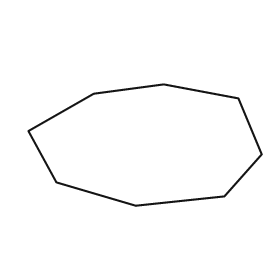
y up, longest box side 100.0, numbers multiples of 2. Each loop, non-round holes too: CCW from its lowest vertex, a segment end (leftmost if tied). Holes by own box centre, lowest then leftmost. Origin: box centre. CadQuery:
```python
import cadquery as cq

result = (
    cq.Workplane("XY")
    .moveTo(-4.0, -26.0)
    .lineTo(34.0, -22.0)
    .lineTo(50.0, -4.0)
    .lineTo(40.0, 20.0)
    .lineTo(8.0, 26.0)
    .lineTo(-22.0, 22.0)
    .lineTo(-50.0, 6.0)
    .lineTo(-38.0, -16.0)
    .close()
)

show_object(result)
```